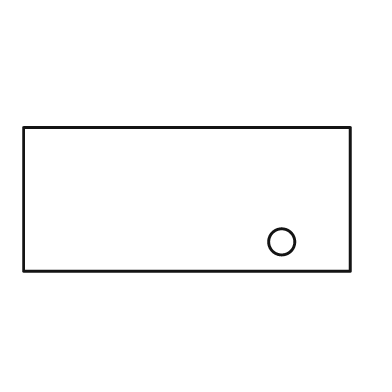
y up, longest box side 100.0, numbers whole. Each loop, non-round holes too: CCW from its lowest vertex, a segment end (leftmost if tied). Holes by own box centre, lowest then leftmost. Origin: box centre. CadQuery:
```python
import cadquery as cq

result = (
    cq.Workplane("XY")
    .moveTo(-50.0, -22.0)
    .lineTo(50.0, -22.0)
    .lineTo(50.0, 22.0)
    .lineTo(-50.0, 22.0)
    .close()
    .moveTo(29.0, -13.0)
    .circle(4.0)
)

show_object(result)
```